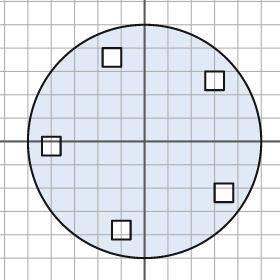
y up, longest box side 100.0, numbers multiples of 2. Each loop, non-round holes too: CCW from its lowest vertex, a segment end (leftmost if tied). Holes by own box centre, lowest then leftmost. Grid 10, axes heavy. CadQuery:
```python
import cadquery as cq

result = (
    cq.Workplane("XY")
    .moveTo(0.0, 0.0)
    .circle(50.0)
    .moveTo(-14.0, -42.0)
    .lineTo(-6.0, -42.0)
    .lineTo(-6.0, -34.0)
    .lineTo(-14.0, -34.0)
    .close()
    .moveTo(30.0, -26.0)
    .lineTo(38.0, -26.0)
    .lineTo(38.0, -18.0)
    .lineTo(30.0, -18.0)
    .close()
    .moveTo(-44.0, -6.0)
    .lineTo(-36.0, -6.0)
    .lineTo(-36.0, 2.0)
    .lineTo(-44.0, 2.0)
    .close()
    .moveTo(26.0, 22.0)
    .lineTo(34.0, 22.0)
    .lineTo(34.0, 30.0)
    .lineTo(26.0, 30.0)
    .close()
    .moveTo(-18.0, 32.0)
    .lineTo(-10.0, 32.0)
    .lineTo(-10.0, 40.0)
    .lineTo(-18.0, 40.0)
    .close()
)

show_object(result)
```